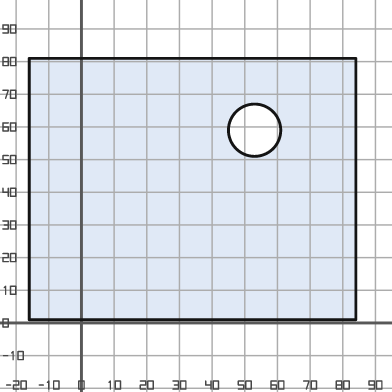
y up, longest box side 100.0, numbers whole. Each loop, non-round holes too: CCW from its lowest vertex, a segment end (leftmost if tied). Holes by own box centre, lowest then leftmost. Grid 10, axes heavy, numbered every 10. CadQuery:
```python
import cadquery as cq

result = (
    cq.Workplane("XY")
    .moveTo(-16.0, 1.0)
    .lineTo(84.0, 1.0)
    .lineTo(84.0, 81.0)
    .lineTo(-16.0, 81.0)
    .close()
    .moveTo(53.0, 59.0)
    .circle(8.0)
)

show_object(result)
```